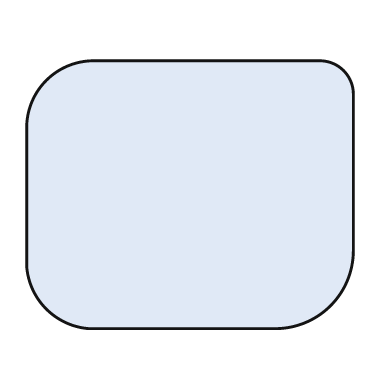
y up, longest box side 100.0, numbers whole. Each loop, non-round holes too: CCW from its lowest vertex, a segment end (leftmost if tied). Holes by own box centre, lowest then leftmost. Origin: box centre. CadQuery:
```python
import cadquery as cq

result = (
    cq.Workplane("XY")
    .moveTo(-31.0, -41.0)
    .lineTo(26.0, -41.0)
    .threePointArc((43.0, -34.0), (50.0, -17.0))
    .lineTo(50.0, 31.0)
    .threePointArc((47.0, 38.0), (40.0, 41.0))
    .lineTo(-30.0, 41.0)
    .threePointArc((-44.0, 35.0), (-50.0, 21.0))
    .lineTo(-50.0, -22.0)
    .threePointArc((-44.0, -35.0), (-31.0, -41.0))
    .close()
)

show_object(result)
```